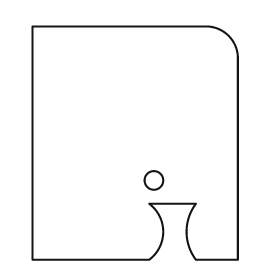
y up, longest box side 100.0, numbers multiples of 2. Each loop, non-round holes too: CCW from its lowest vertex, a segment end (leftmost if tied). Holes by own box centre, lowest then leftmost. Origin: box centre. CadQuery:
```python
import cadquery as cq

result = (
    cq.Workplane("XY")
    .moveTo(-44.0, -50.0)
    .lineTo(6.0, -50.0)
    .threePointArc((12.0, -38.0), (6.0, -26.0))
    .lineTo(26.0, -26.0)
    .threePointArc((22.0, -38.0), (26.0, -50.0))
    .lineTo(44.0, -50.0)
    .lineTo(44.0, 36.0)
    .threePointArc((40.0, 46.0), (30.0, 50.0))
    .lineTo(-44.0, 50.0)
    .close()
    .moveTo(8.0, -16.0)
    .circle(4.0)
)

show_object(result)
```